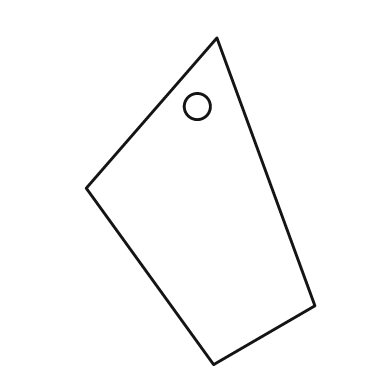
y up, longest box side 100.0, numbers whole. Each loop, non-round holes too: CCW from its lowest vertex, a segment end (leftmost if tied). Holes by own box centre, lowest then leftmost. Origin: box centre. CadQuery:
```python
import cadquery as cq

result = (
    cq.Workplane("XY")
    .moveTo(4.0, -50.0)
    .lineTo(35.0, -32.0)
    .lineTo(5.0, 50.0)
    .lineTo(-35.0, 4.0)
    .close()
    .moveTo(-1.0, 29.0)
    .circle(4.0)
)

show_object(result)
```